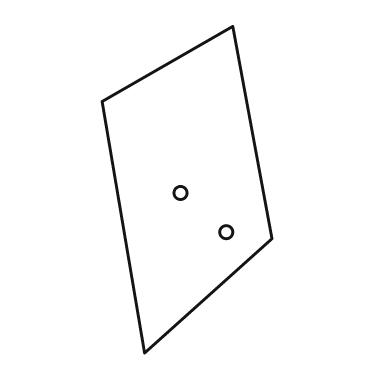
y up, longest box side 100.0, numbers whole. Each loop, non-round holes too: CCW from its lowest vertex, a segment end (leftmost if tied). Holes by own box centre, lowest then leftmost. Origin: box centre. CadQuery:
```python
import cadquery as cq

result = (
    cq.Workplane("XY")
    .moveTo(-13.0, -50.0)
    .lineTo(26.0, -15.0)
    .lineTo(14.0, 50.0)
    .lineTo(-26.0, 27.0)
    .close()
    .moveTo(12.0, -13.0)
    .circle(2.0)
    .moveTo(-2.0, -1.0)
    .circle(2.0)
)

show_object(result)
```